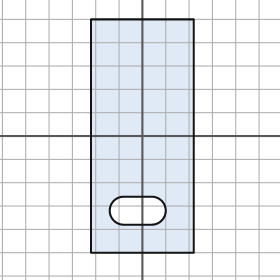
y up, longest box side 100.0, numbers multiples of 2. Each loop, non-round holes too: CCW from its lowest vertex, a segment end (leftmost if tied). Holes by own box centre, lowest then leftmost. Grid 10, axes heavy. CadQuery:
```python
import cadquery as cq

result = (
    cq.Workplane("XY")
    .moveTo(-22.0, -50.0)
    .lineTo(22.0, -50.0)
    .lineTo(22.0, 50.0)
    .lineTo(-22.0, 50.0)
    .close()
    .moveTo(-8.0, -38.0)
    .lineTo(4.0, -38.0)
    .threePointArc((10.0, -32.0), (4.0, -26.0))
    .lineTo(-8.0, -26.0)
    .threePointArc((-14.0, -32.0), (-8.0, -38.0))
    .close()
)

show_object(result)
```